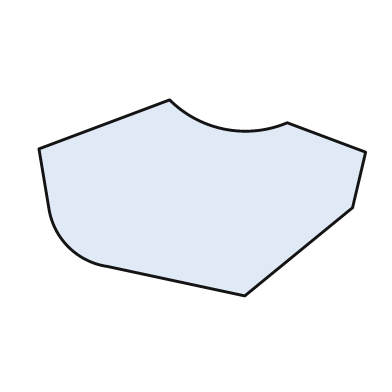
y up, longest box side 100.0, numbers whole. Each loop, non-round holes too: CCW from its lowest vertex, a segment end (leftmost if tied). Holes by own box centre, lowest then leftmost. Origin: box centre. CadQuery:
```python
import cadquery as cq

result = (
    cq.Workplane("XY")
    .moveTo(13.0, -30.0)
    .lineTo(46.0, -3.0)
    .lineTo(50.0, 14.0)
    .lineTo(26.0, 23.0)
    .threePointArc((7.0, 21.0), (-10.0, 30.0))
    .lineTo(-50.0, 15.0)
    .lineTo(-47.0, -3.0)
    .threePointArc((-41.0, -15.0), (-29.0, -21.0))
    .close()
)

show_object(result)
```